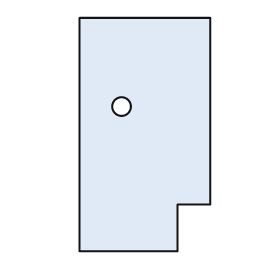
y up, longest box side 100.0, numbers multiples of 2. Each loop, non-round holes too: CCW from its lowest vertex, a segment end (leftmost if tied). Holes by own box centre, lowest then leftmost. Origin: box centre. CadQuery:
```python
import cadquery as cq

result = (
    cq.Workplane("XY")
    .moveTo(-28.0, -50.0)
    .lineTo(14.0, -50.0)
    .lineTo(14.0, -30.0)
    .lineTo(28.0, -30.0)
    .lineTo(28.0, 50.0)
    .lineTo(-28.0, 50.0)
    .close()
    .moveTo(-10.0, 12.0)
    .circle(4.0)
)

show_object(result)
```